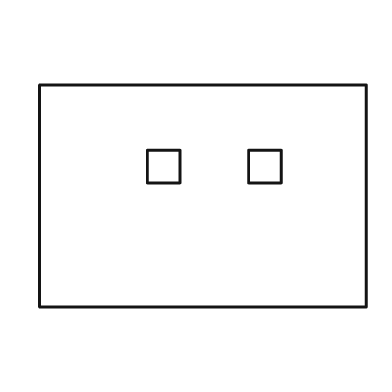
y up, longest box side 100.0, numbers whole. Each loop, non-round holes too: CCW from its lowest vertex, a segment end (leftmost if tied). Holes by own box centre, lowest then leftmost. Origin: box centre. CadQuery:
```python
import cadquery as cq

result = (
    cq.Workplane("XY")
    .moveTo(-50.0, -34.0)
    .lineTo(50.0, -34.0)
    .lineTo(50.0, 34.0)
    .lineTo(-50.0, 34.0)
    .close()
    .moveTo(-17.0, 4.0)
    .lineTo(-7.0, 4.0)
    .lineTo(-7.0, 14.0)
    .lineTo(-17.0, 14.0)
    .close()
    .moveTo(14.0, 4.0)
    .lineTo(24.0, 4.0)
    .lineTo(24.0, 14.0)
    .lineTo(14.0, 14.0)
    .close()
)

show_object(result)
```